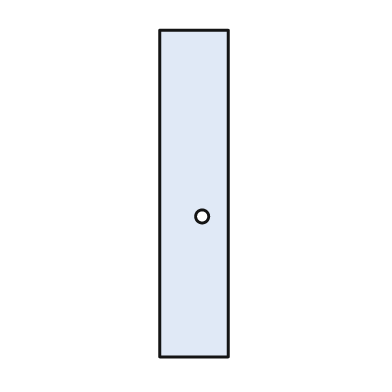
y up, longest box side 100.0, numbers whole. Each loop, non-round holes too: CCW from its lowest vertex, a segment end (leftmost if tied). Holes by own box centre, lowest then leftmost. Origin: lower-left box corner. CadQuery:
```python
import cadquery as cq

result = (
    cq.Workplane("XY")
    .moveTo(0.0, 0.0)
    .lineTo(21.0, 0.0)
    .lineTo(21.0, 100.0)
    .lineTo(0.0, 100.0)
    .close()
    .moveTo(13.0, 43.0)
    .circle(2.0)
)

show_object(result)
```